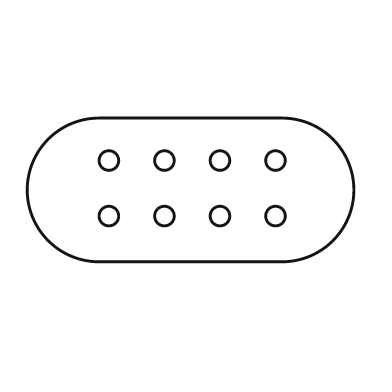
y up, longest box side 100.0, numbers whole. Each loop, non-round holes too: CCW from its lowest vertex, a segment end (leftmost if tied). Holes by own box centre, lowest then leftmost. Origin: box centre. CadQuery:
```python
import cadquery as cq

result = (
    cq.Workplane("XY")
    .moveTo(-28.0, -22.0)
    .lineTo(28.0, -22.0)
    .threePointArc((50.0, 0.0), (28.0, 22.0))
    .lineTo(-28.0, 22.0)
    .threePointArc((-50.0, 0.0), (-28.0, -22.0))
    .close()
    .moveTo(-25.0, -8.0)
    .circle(3.0)
    .moveTo(-8.0, -8.0)
    .circle(3.0)
    .moveTo(9.0, -8.0)
    .circle(3.0)
    .moveTo(26.0, -8.0)
    .circle(3.0)
    .moveTo(-25.0, 9.0)
    .circle(3.0)
    .moveTo(-8.0, 9.0)
    .circle(3.0)
    .moveTo(9.0, 9.0)
    .circle(3.0)
    .moveTo(26.0, 9.0)
    .circle(3.0)
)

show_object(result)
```